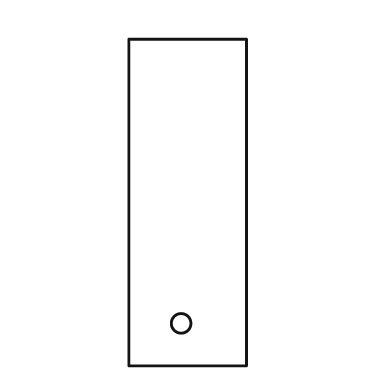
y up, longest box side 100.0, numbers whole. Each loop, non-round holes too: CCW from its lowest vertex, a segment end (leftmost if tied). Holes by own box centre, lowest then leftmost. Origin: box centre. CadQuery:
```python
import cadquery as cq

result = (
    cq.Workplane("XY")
    .moveTo(-18.0, -50.0)
    .lineTo(18.0, -50.0)
    .lineTo(18.0, 50.0)
    .lineTo(-18.0, 50.0)
    .close()
    .moveTo(-2.0, -37.0)
    .circle(3.0)
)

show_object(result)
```